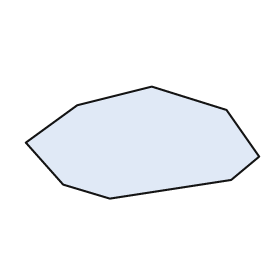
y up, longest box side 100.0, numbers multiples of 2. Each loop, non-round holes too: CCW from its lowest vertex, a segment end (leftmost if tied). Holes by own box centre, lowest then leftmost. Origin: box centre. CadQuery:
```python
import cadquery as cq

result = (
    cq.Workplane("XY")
    .moveTo(-14.0, -24.0)
    .lineTo(38.0, -16.0)
    .lineTo(50.0, -6.0)
    .lineTo(36.0, 14.0)
    .lineTo(4.0, 24.0)
    .lineTo(-28.0, 16.0)
    .lineTo(-50.0, 0.0)
    .lineTo(-34.0, -18.0)
    .close()
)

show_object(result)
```